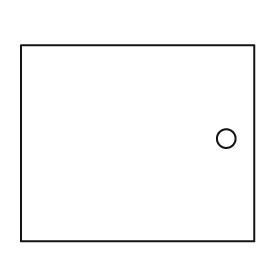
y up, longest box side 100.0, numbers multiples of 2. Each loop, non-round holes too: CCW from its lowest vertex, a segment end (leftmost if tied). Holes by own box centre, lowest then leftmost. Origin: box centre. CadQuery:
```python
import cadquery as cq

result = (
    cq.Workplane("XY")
    .moveTo(-50.0, -42.0)
    .lineTo(50.0, -42.0)
    .lineTo(50.0, 42.0)
    .lineTo(-50.0, 42.0)
    .close()
    .moveTo(38.0, 2.0)
    .circle(4.0)
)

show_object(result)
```